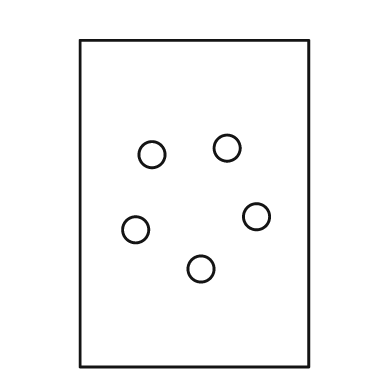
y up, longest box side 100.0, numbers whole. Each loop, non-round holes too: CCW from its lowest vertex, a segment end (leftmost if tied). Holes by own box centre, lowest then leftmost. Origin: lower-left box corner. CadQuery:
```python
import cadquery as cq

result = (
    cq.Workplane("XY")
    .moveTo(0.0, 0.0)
    .lineTo(70.0, 0.0)
    .lineTo(70.0, 100.0)
    .lineTo(0.0, 100.0)
    .close()
    .moveTo(37.0, 30.0)
    .circle(4.0)
    .moveTo(17.0, 42.0)
    .circle(4.0)
    .moveTo(54.0, 46.0)
    .circle(4.0)
    .moveTo(22.0, 65.0)
    .circle(4.0)
    .moveTo(45.0, 67.0)
    .circle(4.0)
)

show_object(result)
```